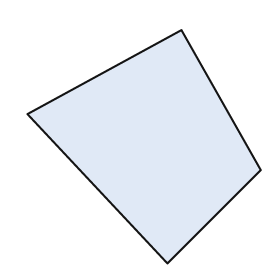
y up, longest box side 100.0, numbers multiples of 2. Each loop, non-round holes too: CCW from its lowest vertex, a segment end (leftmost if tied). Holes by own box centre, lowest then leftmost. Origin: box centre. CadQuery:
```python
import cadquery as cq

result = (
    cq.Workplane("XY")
    .moveTo(10.0, -50.0)
    .lineTo(50.0, -10.0)
    .lineTo(16.0, 50.0)
    .lineTo(-50.0, 14.0)
    .close()
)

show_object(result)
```